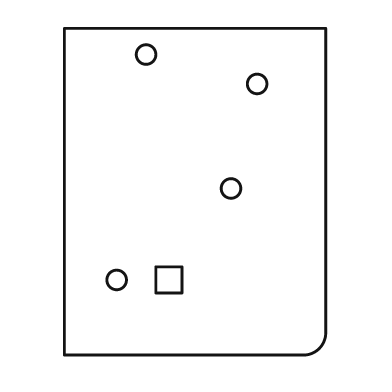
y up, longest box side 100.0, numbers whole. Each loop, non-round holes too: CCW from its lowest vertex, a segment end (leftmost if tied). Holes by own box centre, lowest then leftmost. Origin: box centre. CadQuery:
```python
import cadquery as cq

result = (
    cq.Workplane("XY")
    .moveTo(-40.0, -50.0)
    .lineTo(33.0, -50.0)
    .threePointArc((38.0, -48.0), (40.0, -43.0))
    .lineTo(40.0, 50.0)
    .lineTo(-40.0, 50.0)
    .close()
    .moveTo(-24.0, -27.0)
    .circle(3.0)
    .moveTo(-12.0, -31.0)
    .lineTo(-4.0, -31.0)
    .lineTo(-4.0, -23.0)
    .lineTo(-12.0, -23.0)
    .close()
    .moveTo(11.0, 1.0)
    .circle(3.0)
    .moveTo(19.0, 33.0)
    .circle(3.0)
    .moveTo(-15.0, 42.0)
    .circle(3.0)
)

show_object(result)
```